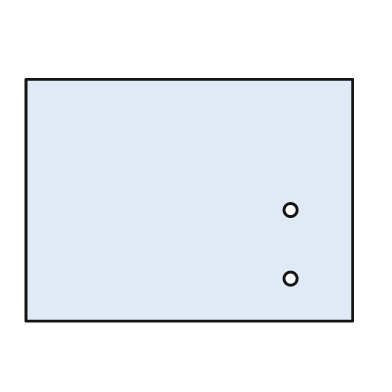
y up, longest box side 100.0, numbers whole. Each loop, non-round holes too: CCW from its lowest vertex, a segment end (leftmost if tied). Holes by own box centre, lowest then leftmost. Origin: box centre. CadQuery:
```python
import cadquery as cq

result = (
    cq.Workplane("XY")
    .moveTo(-50.0, -37.0)
    .lineTo(50.0, -37.0)
    .lineTo(50.0, 37.0)
    .lineTo(-50.0, 37.0)
    .close()
    .moveTo(31.0, -24.0)
    .circle(2.0)
    .moveTo(31.0, -3.0)
    .circle(2.0)
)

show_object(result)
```